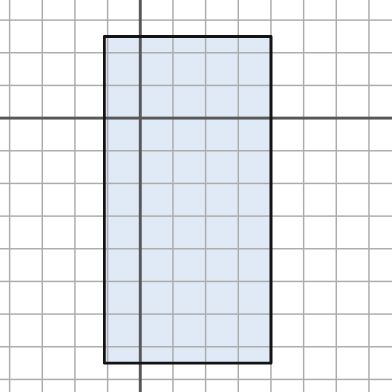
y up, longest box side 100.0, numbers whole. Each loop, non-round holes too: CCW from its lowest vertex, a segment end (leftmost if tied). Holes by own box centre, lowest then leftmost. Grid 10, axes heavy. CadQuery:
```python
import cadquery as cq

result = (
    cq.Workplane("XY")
    .moveTo(-11.0, -75.0)
    .lineTo(40.0, -75.0)
    .lineTo(40.0, 25.0)
    .lineTo(-11.0, 25.0)
    .close()
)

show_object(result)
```